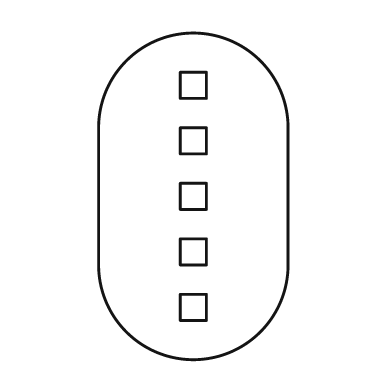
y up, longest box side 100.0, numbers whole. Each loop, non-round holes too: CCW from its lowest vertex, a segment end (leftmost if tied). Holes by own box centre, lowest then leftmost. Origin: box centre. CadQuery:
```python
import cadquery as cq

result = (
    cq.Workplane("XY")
    .moveTo(-29.0, -21.0)
    .threePointArc((0.0, -50.0), (29.0, -21.0))
    .lineTo(29.0, 21.0)
    .threePointArc((0.0, 50.0), (-29.0, 21.0))
    .close()
    .moveTo(-4.0, -38.0)
    .lineTo(4.0, -38.0)
    .lineTo(4.0, -30.0)
    .lineTo(-4.0, -30.0)
    .close()
    .moveTo(-4.0, -21.0)
    .lineTo(4.0, -21.0)
    .lineTo(4.0, -13.0)
    .lineTo(-4.0, -13.0)
    .close()
    .moveTo(-4.0, -4.0)
    .lineTo(4.0, -4.0)
    .lineTo(4.0, 4.0)
    .lineTo(-4.0, 4.0)
    .close()
    .moveTo(-4.0, 13.0)
    .lineTo(4.0, 13.0)
    .lineTo(4.0, 21.0)
    .lineTo(-4.0, 21.0)
    .close()
    .moveTo(-4.0, 30.0)
    .lineTo(4.0, 30.0)
    .lineTo(4.0, 38.0)
    .lineTo(-4.0, 38.0)
    .close()
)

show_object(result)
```